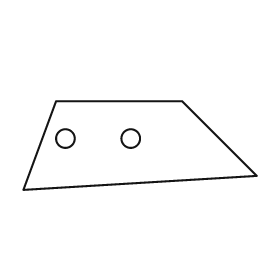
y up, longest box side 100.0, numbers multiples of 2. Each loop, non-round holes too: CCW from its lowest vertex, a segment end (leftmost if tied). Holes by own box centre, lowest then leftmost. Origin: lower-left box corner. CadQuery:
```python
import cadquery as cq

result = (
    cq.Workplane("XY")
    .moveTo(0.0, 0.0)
    .lineTo(100.0, 6.0)
    .lineTo(68.0, 38.0)
    .lineTo(14.0, 38.0)
    .close()
    .moveTo(18.0, 22.0)
    .circle(4.0)
    .moveTo(46.0, 22.0)
    .circle(4.0)
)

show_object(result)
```